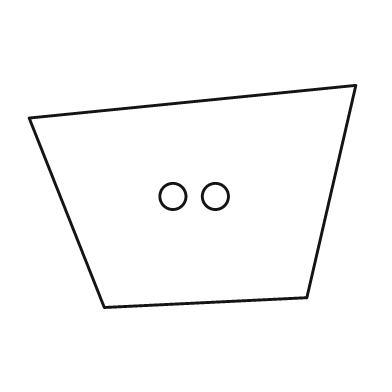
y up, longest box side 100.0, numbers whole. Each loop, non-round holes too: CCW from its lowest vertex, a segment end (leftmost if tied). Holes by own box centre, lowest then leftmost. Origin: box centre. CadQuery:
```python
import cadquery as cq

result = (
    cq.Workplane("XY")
    .moveTo(-27.0, -34.0)
    .lineTo(35.0, -31.0)
    .lineTo(50.0, 34.0)
    .lineTo(-50.0, 24.0)
    .close()
    .moveTo(-6.0, 0.0)
    .circle(4.0)
    .moveTo(7.0, 0.0)
    .circle(4.0)
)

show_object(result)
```